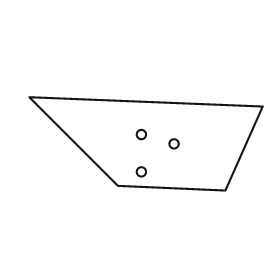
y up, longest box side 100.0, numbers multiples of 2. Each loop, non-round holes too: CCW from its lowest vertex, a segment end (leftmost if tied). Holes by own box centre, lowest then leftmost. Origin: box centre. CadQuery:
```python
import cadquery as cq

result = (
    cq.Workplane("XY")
    .moveTo(34.0, -20.0)
    .lineTo(50.0, 16.0)
    .lineTo(-50.0, 20.0)
    .lineTo(-12.0, -18.0)
    .close()
    .moveTo(-2.0, -12.0)
    .circle(2.0)
    .moveTo(12.0, 0.0)
    .circle(2.0)
    .moveTo(-2.0, 4.0)
    .circle(2.0)
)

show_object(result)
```